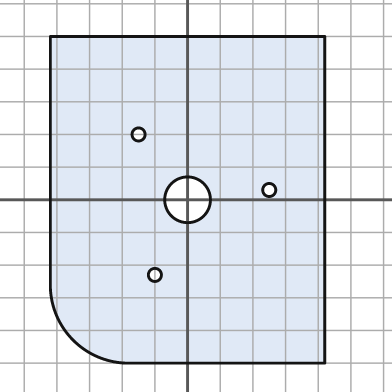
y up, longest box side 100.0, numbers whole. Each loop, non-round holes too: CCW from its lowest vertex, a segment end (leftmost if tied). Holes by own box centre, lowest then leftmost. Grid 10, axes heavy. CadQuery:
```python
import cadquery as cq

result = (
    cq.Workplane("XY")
    .moveTo(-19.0, -50.0)
    .lineTo(42.0, -50.0)
    .lineTo(42.0, 50.0)
    .lineTo(-42.0, 50.0)
    .lineTo(-42.0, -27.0)
    .threePointArc((-35.0, -43.0), (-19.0, -50.0))
    .close()
    .moveTo(-10.0, -23.0)
    .circle(2.0)
    .moveTo(0.0, 0.0)
    .circle(7.0)
    .moveTo(25.0, 3.0)
    .circle(2.0)
    .moveTo(-15.0, 20.0)
    .circle(2.0)
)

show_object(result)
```